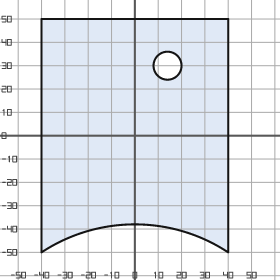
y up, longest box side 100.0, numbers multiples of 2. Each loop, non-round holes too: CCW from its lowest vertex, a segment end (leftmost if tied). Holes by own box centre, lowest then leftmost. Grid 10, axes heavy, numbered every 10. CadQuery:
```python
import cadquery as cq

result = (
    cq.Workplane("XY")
    .moveTo(-40.0, -50.0)
    .threePointArc((0.0, -38.0), (40.0, -50.0))
    .lineTo(40.0, 50.0)
    .lineTo(-40.0, 50.0)
    .close()
    .moveTo(14.0, 30.0)
    .circle(6.0)
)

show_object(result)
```